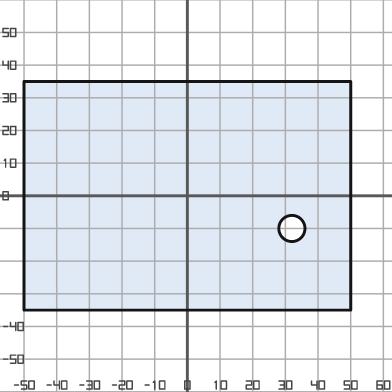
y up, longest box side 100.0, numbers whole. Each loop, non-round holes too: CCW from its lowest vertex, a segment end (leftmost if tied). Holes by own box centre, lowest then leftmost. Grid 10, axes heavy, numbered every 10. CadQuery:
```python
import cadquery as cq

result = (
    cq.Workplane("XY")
    .moveTo(-50.0, -35.0)
    .lineTo(50.0, -35.0)
    .lineTo(50.0, 35.0)
    .lineTo(-50.0, 35.0)
    .close()
    .moveTo(32.0, -10.0)
    .circle(4.0)
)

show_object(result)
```